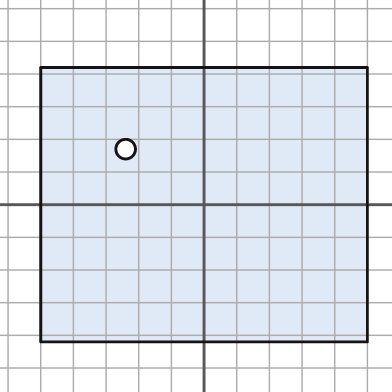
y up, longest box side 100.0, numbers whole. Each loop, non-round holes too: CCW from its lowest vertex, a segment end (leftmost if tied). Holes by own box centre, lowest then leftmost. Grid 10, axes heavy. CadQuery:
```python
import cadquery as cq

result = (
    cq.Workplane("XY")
    .moveTo(-50.0, -42.0)
    .lineTo(50.0, -42.0)
    .lineTo(50.0, 42.0)
    .lineTo(-50.0, 42.0)
    .close()
    .moveTo(-24.0, 17.0)
    .circle(3.0)
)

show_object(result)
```